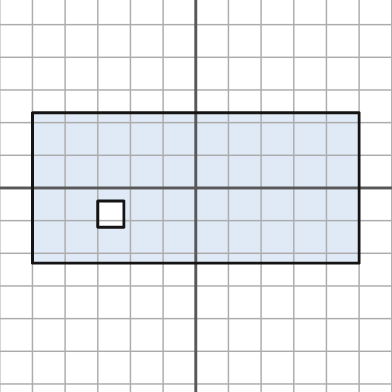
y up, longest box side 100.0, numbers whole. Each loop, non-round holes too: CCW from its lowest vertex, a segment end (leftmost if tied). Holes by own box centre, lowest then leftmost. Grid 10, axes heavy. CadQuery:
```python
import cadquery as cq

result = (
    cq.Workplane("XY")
    .moveTo(-50.0, -23.0)
    .lineTo(50.0, -23.0)
    .lineTo(50.0, 23.0)
    .lineTo(-50.0, 23.0)
    .close()
    .moveTo(-30.0, -12.0)
    .lineTo(-22.0, -12.0)
    .lineTo(-22.0, -4.0)
    .lineTo(-30.0, -4.0)
    .close()
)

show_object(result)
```